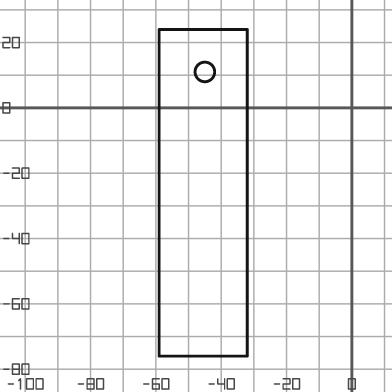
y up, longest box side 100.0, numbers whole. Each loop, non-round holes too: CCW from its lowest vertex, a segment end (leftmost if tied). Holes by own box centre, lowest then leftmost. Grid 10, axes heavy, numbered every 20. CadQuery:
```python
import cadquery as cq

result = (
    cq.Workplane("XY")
    .moveTo(-59.0, -76.0)
    .lineTo(-32.0, -76.0)
    .lineTo(-32.0, 24.0)
    .lineTo(-59.0, 24.0)
    .close()
    .moveTo(-45.0, 11.0)
    .circle(3.0)
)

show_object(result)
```